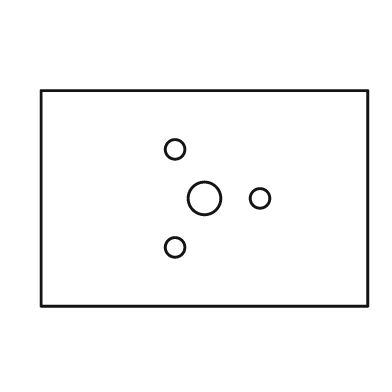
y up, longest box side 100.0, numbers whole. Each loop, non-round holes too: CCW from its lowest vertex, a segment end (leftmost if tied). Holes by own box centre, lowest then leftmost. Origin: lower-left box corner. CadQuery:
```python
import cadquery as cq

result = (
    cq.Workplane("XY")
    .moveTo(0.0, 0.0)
    .lineTo(100.0, 0.0)
    .lineTo(100.0, 66.0)
    .lineTo(0.0, 66.0)
    .close()
    .moveTo(41.0, 18.0)
    .circle(3.0)
    .moveTo(50.0, 33.0)
    .circle(5.0)
    .moveTo(67.0, 33.0)
    .circle(3.0)
    .moveTo(41.0, 48.0)
    .circle(3.0)
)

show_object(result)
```